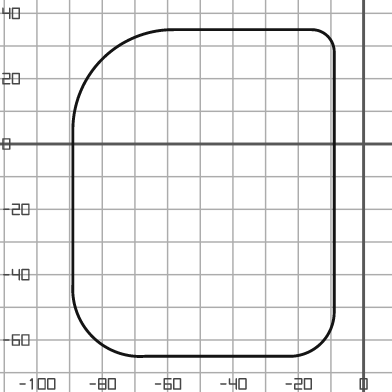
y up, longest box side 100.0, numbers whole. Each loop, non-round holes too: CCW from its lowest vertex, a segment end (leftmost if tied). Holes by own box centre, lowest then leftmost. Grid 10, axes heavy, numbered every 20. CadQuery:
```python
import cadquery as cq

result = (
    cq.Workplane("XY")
    .moveTo(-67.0, -65.0)
    .lineTo(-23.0, -65.0)
    .threePointArc((-13.0, -61.0), (-9.0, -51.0))
    .lineTo(-9.0, 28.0)
    .threePointArc((-11.0, 33.0), (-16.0, 35.0))
    .lineTo(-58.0, 35.0)
    .threePointArc((-80.0, 26.0), (-89.0, 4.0))
    .lineTo(-89.0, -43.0)
    .threePointArc((-83.0, -59.0), (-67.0, -65.0))
    .close()
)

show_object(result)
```